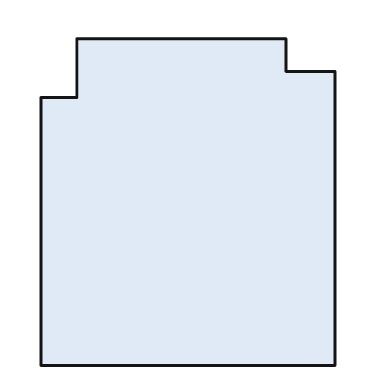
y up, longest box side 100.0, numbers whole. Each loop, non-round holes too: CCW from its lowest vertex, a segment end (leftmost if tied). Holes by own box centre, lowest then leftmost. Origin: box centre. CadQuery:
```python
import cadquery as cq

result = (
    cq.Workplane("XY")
    .moveTo(-45.0, -50.0)
    .lineTo(45.0, -50.0)
    .lineTo(45.0, 40.0)
    .lineTo(30.0, 40.0)
    .lineTo(30.0, 50.0)
    .lineTo(-34.0, 50.0)
    .lineTo(-34.0, 32.0)
    .lineTo(-45.0, 32.0)
    .close()
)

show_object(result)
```